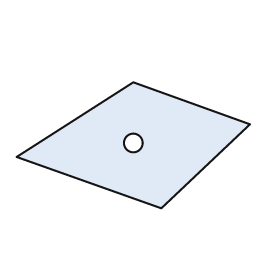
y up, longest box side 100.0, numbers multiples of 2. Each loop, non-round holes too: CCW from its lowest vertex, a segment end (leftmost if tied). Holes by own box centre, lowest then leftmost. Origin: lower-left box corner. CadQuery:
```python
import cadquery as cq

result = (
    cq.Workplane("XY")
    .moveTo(62.0, 0.0)
    .lineTo(100.0, 36.0)
    .lineTo(50.0, 54.0)
    .lineTo(0.0, 22.0)
    .close()
    .moveTo(50.0, 28.0)
    .circle(4.0)
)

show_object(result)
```